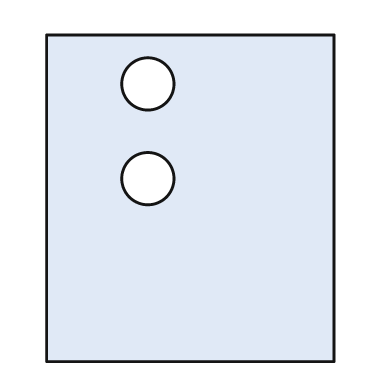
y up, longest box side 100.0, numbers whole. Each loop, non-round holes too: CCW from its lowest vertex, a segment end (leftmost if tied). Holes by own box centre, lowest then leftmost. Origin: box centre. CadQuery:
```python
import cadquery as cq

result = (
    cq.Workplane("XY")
    .moveTo(-44.0, -50.0)
    .lineTo(44.0, -50.0)
    .lineTo(44.0, 50.0)
    .lineTo(-44.0, 50.0)
    .close()
    .moveTo(-13.0, 6.0)
    .circle(8.0)
    .moveTo(-13.0, 35.0)
    .circle(8.0)
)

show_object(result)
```